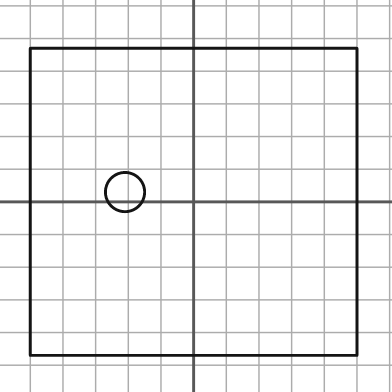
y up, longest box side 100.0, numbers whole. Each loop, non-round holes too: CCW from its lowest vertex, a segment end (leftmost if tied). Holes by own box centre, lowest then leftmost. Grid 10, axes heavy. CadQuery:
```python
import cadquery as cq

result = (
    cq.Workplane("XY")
    .moveTo(-50.0, -47.0)
    .lineTo(50.0, -47.0)
    .lineTo(50.0, 47.0)
    .lineTo(-50.0, 47.0)
    .close()
    .moveTo(-21.0, 3.0)
    .circle(6.0)
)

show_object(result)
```